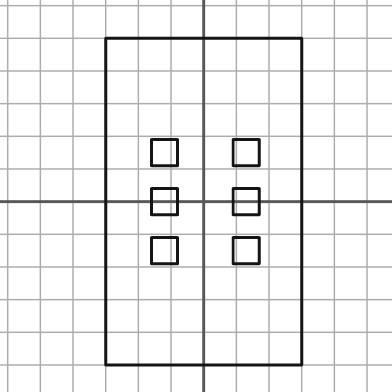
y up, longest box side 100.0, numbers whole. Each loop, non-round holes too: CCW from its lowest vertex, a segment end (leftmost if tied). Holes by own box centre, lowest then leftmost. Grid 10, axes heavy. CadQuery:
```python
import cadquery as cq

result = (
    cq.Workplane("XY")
    .moveTo(-30.0, -50.0)
    .lineTo(30.0, -50.0)
    .lineTo(30.0, 50.0)
    .lineTo(-30.0, 50.0)
    .close()
    .moveTo(-16.0, -19.0)
    .lineTo(-8.0, -19.0)
    .lineTo(-8.0, -11.0)
    .lineTo(-16.0, -11.0)
    .close()
    .moveTo(9.0, -19.0)
    .lineTo(17.0, -19.0)
    .lineTo(17.0, -11.0)
    .lineTo(9.0, -11.0)
    .close()
    .moveTo(-16.0, -4.0)
    .lineTo(-8.0, -4.0)
    .lineTo(-8.0, 4.0)
    .lineTo(-16.0, 4.0)
    .close()
    .moveTo(9.0, -4.0)
    .lineTo(17.0, -4.0)
    .lineTo(17.0, 4.0)
    .lineTo(9.0, 4.0)
    .close()
    .moveTo(-16.0, 11.0)
    .lineTo(-8.0, 11.0)
    .lineTo(-8.0, 19.0)
    .lineTo(-16.0, 19.0)
    .close()
    .moveTo(9.0, 11.0)
    .lineTo(17.0, 11.0)
    .lineTo(17.0, 19.0)
    .lineTo(9.0, 19.0)
    .close()
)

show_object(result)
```